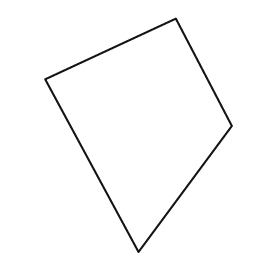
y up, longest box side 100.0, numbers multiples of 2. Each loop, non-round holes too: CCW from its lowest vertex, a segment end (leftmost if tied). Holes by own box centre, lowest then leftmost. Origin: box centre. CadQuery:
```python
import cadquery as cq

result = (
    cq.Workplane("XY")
    .moveTo(0.0, -50.0)
    .lineTo(40.0, 4.0)
    .lineTo(16.0, 50.0)
    .lineTo(-40.0, 24.0)
    .close()
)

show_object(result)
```